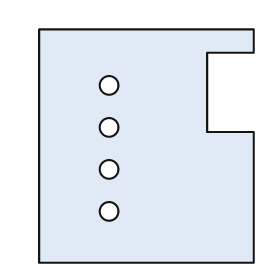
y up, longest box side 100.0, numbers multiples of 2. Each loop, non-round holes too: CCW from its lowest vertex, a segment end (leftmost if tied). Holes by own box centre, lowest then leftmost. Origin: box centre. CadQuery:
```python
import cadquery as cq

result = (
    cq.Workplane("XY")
    .moveTo(-46.0, -50.0)
    .lineTo(46.0, -50.0)
    .lineTo(46.0, 6.0)
    .lineTo(26.0, 6.0)
    .lineTo(26.0, 40.0)
    .lineTo(46.0, 40.0)
    .lineTo(46.0, 50.0)
    .lineTo(-46.0, 50.0)
    .close()
    .moveTo(-16.0, -28.0)
    .circle(4.0)
    .moveTo(-16.0, -10.0)
    .circle(4.0)
    .moveTo(-16.0, 8.0)
    .circle(4.0)
    .moveTo(-16.0, 26.0)
    .circle(4.0)
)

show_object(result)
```